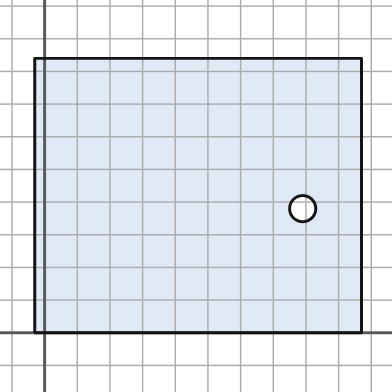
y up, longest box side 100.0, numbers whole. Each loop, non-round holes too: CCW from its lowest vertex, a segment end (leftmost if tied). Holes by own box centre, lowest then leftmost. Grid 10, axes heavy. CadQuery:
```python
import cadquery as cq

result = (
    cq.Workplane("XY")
    .moveTo(-3.0, 0.0)
    .lineTo(97.0, 0.0)
    .lineTo(97.0, 84.0)
    .lineTo(-3.0, 84.0)
    .close()
    .moveTo(79.0, 38.0)
    .circle(4.0)
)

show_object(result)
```